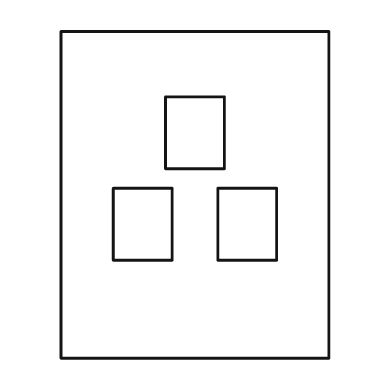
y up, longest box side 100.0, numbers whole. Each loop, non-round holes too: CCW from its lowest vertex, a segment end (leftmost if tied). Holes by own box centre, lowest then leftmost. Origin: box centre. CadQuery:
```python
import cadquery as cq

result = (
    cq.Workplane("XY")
    .moveTo(-41.0, -50.0)
    .lineTo(41.0, -50.0)
    .lineTo(41.0, 50.0)
    .lineTo(-41.0, 50.0)
    .close()
    .moveTo(-25.0, -20.0)
    .lineTo(-7.0, -20.0)
    .lineTo(-7.0, 2.0)
    .lineTo(-25.0, 2.0)
    .close()
    .moveTo(7.0, -20.0)
    .lineTo(25.0, -20.0)
    .lineTo(25.0, 2.0)
    .lineTo(7.0, 2.0)
    .close()
    .moveTo(-9.0, 8.0)
    .lineTo(9.0, 8.0)
    .lineTo(9.0, 30.0)
    .lineTo(-9.0, 30.0)
    .close()
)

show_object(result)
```